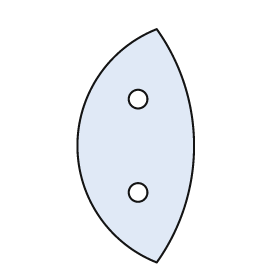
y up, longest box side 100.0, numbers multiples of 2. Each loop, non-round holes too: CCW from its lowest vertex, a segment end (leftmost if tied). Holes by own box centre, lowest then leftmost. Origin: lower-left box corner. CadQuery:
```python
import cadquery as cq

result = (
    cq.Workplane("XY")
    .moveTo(34.0, 0.0)
    .threePointArc((50.0, 50.0), (34.0, 100.0))
    .threePointArc((0.0, 50.0), (34.0, 0.0))
    .close()
    .moveTo(26.0, 30.0)
    .circle(4.0)
    .moveTo(26.0, 70.0)
    .circle(4.0)
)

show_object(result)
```